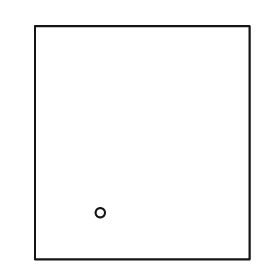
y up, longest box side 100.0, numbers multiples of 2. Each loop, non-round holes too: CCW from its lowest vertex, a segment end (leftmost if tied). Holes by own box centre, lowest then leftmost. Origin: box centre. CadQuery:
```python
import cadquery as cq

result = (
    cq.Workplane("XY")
    .moveTo(-46.0, -50.0)
    .lineTo(46.0, -50.0)
    .lineTo(46.0, 50.0)
    .lineTo(-46.0, 50.0)
    .close()
    .moveTo(-18.0, -30.0)
    .circle(2.0)
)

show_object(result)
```